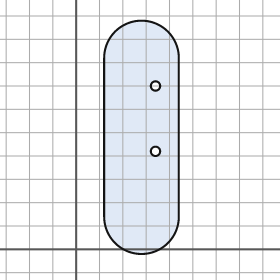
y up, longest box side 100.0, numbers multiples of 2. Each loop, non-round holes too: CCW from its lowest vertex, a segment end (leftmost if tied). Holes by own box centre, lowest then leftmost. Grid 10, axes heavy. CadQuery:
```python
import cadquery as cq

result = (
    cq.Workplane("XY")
    .moveTo(12.0, 14.0)
    .threePointArc((28.0, -2.0), (44.0, 14.0))
    .lineTo(44.0, 82.0)
    .threePointArc((28.0, 98.0), (12.0, 82.0))
    .close()
    .moveTo(34.0, 42.0)
    .circle(2.0)
    .moveTo(34.0, 70.0)
    .circle(2.0)
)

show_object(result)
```